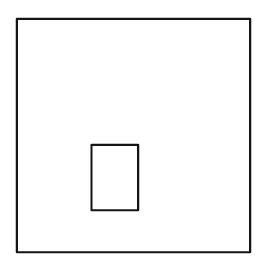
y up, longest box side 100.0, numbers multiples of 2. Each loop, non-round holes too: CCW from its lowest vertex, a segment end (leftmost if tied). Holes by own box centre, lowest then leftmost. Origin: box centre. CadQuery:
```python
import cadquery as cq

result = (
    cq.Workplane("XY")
    .moveTo(-50.0, -50.0)
    .lineTo(50.0, -50.0)
    .lineTo(50.0, 50.0)
    .lineTo(-50.0, 50.0)
    .close()
    .moveTo(-18.0, -32.0)
    .lineTo(2.0, -32.0)
    .lineTo(2.0, -4.0)
    .lineTo(-18.0, -4.0)
    .close()
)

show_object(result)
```